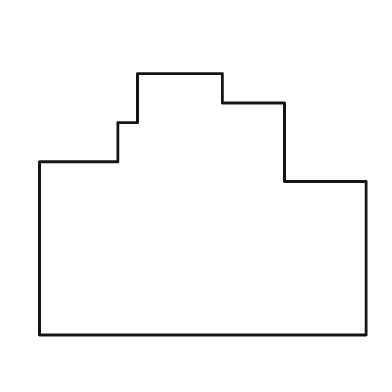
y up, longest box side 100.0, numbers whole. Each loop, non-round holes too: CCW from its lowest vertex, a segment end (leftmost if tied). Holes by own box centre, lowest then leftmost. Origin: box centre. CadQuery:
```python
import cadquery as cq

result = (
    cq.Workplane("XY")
    .moveTo(-50.0, -40.0)
    .lineTo(50.0, -40.0)
    .lineTo(50.0, 7.0)
    .lineTo(25.0, 7.0)
    .lineTo(25.0, 31.0)
    .lineTo(6.0, 31.0)
    .lineTo(6.0, 40.0)
    .lineTo(-20.0, 40.0)
    .lineTo(-20.0, 25.0)
    .lineTo(-26.0, 25.0)
    .lineTo(-26.0, 13.0)
    .lineTo(-50.0, 13.0)
    .close()
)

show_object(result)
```